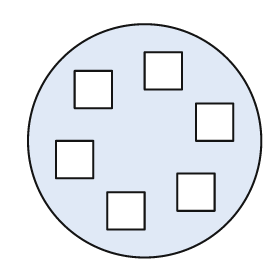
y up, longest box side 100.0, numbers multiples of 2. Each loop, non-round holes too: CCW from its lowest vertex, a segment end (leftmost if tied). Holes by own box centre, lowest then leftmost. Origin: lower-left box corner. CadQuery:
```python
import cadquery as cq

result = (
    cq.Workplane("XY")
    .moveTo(50.0, 50.0)
    .circle(50.0)
    .moveTo(34.0, 12.0)
    .lineTo(50.0, 12.0)
    .lineTo(50.0, 28.0)
    .lineTo(34.0, 28.0)
    .close()
    .moveTo(64.0, 20.0)
    .lineTo(80.0, 20.0)
    .lineTo(80.0, 36.0)
    .lineTo(64.0, 36.0)
    .close()
    .moveTo(12.0, 34.0)
    .lineTo(28.0, 34.0)
    .lineTo(28.0, 50.0)
    .lineTo(12.0, 50.0)
    .close()
    .moveTo(72.0, 50.0)
    .lineTo(88.0, 50.0)
    .lineTo(88.0, 66.0)
    .lineTo(72.0, 66.0)
    .close()
    .moveTo(20.0, 64.0)
    .lineTo(36.0, 64.0)
    .lineTo(36.0, 80.0)
    .lineTo(20.0, 80.0)
    .close()
    .moveTo(50.0, 72.0)
    .lineTo(66.0, 72.0)
    .lineTo(66.0, 88.0)
    .lineTo(50.0, 88.0)
    .close()
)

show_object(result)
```